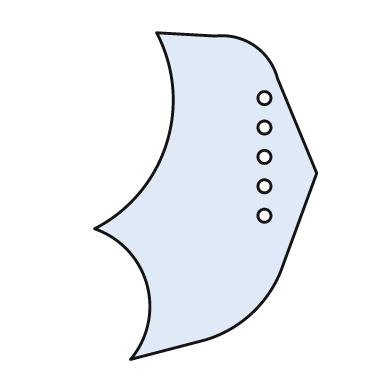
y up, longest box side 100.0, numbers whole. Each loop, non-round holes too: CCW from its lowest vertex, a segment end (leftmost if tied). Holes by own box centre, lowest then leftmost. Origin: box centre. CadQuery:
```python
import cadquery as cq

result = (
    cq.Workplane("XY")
    .moveTo(-23.0, -50.0)
    .lineTo(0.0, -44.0)
    .threePointArc((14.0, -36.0), (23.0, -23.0))
    .lineTo(34.0, 7.0)
    .lineTo(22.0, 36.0)
    .threePointArc((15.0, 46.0), (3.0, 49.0))
    .lineTo(-15.0, 50.0)
    .threePointArc((-12.0, 16.0), (-34.0, -10.0))
    .threePointArc((-18.0, -27.0), (-23.0, -50.0))
    .close()
    .moveTo(18.0, -6.0)
    .circle(2.0)
    .moveTo(18.0, 3.0)
    .circle(2.0)
    .moveTo(18.0, 12.0)
    .circle(2.0)
    .moveTo(18.0, 21.0)
    .circle(2.0)
    .moveTo(18.0, 30.0)
    .circle(2.0)
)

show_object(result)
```